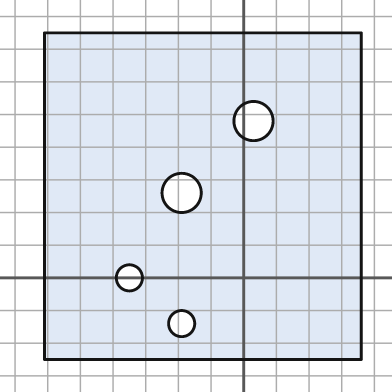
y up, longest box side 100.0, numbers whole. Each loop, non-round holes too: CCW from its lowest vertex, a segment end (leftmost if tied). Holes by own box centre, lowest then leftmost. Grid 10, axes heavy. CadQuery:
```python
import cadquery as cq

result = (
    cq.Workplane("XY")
    .moveTo(-61.0, -25.0)
    .lineTo(36.0, -25.0)
    .lineTo(36.0, 75.0)
    .lineTo(-61.0, 75.0)
    .close()
    .moveTo(-19.0, -14.0)
    .circle(4.0)
    .moveTo(-35.0, 0.0)
    .circle(4.0)
    .moveTo(-19.0, 26.0)
    .circle(6.0)
    .moveTo(3.0, 48.0)
    .circle(6.0)
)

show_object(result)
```